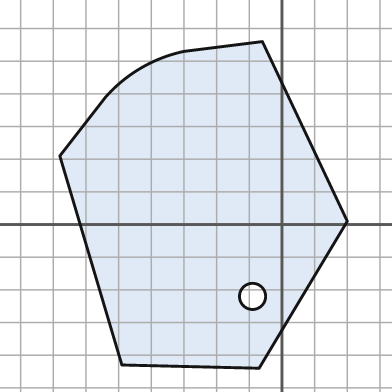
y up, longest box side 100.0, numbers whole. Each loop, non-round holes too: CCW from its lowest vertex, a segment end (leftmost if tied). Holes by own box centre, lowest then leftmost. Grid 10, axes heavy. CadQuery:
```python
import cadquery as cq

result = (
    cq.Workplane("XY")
    .moveTo(-7.0, -44.0)
    .lineTo(20.0, 1.0)
    .lineTo(-6.0, 56.0)
    .lineTo(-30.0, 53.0)
    .threePointArc((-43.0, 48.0), (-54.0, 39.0))
    .lineTo(-68.0, 21.0)
    .lineTo(-49.0, -43.0)
    .close()
    .moveTo(-9.0, -22.0)
    .circle(4.0)
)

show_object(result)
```